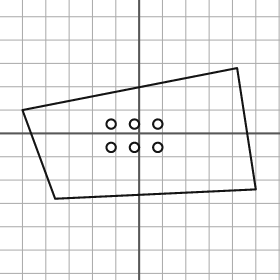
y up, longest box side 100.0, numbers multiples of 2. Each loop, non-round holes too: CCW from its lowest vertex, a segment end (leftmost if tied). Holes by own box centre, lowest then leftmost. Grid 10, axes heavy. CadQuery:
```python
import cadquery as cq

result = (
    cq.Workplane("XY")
    .moveTo(-36.0, -28.0)
    .lineTo(50.0, -24.0)
    .lineTo(42.0, 28.0)
    .lineTo(-50.0, 10.0)
    .close()
    .moveTo(-12.0, -6.0)
    .circle(2.0)
    .moveTo(-2.0, -6.0)
    .circle(2.0)
    .moveTo(8.0, -6.0)
    .circle(2.0)
    .moveTo(-12.0, 4.0)
    .circle(2.0)
    .moveTo(-2.0, 4.0)
    .circle(2.0)
    .moveTo(8.0, 4.0)
    .circle(2.0)
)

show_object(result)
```